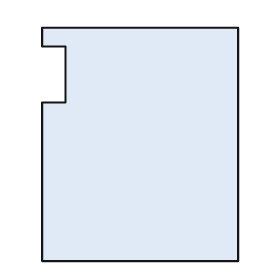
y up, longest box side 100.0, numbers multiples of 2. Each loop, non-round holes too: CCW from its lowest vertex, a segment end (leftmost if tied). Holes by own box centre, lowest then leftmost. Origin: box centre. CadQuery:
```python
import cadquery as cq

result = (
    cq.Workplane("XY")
    .moveTo(-42.0, -50.0)
    .lineTo(42.0, -50.0)
    .lineTo(42.0, 50.0)
    .lineTo(-42.0, 50.0)
    .lineTo(-42.0, 42.0)
    .lineTo(-32.0, 42.0)
    .lineTo(-32.0, 18.0)
    .lineTo(-42.0, 18.0)
    .close()
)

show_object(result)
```